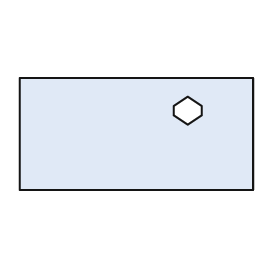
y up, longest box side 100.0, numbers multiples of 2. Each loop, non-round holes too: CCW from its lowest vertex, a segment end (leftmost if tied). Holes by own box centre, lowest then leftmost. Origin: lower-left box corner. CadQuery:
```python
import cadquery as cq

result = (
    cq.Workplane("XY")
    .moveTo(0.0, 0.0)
    .lineTo(100.0, 0.0)
    .lineTo(100.0, 48.0)
    .lineTo(0.0, 48.0)
    .close()
    .moveTo(72.0, 28.0)
    .lineTo(78.0, 32.0)
    .lineTo(78.0, 36.0)
    .lineTo(72.0, 40.0)
    .lineTo(66.0, 36.0)
    .lineTo(66.0, 32.0)
    .close()
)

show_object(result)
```